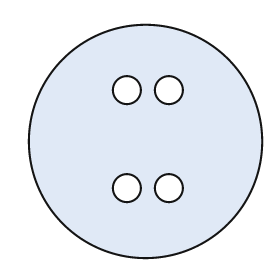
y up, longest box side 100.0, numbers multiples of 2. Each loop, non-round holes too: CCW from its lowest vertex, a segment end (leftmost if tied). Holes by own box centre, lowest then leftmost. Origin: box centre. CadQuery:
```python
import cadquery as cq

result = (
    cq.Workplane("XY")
    .moveTo(0.0, 0.0)
    .circle(50.0)
    .moveTo(-8.0, -20.0)
    .circle(6.0)
    .moveTo(10.0, -20.0)
    .circle(6.0)
    .moveTo(-8.0, 22.0)
    .circle(6.0)
    .moveTo(10.0, 22.0)
    .circle(6.0)
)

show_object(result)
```